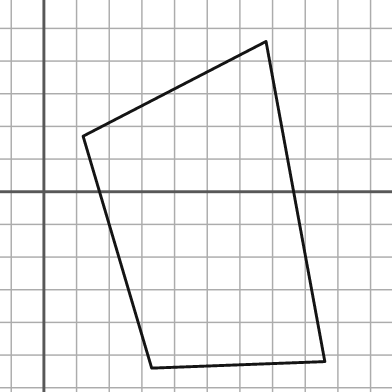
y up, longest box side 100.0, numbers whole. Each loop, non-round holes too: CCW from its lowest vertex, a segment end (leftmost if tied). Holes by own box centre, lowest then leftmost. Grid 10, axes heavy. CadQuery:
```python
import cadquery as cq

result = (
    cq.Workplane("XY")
    .moveTo(33.0, -54.0)
    .lineTo(86.0, -52.0)
    .lineTo(68.0, 46.0)
    .lineTo(12.0, 17.0)
    .close()
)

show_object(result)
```